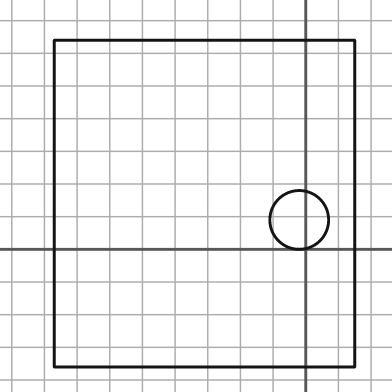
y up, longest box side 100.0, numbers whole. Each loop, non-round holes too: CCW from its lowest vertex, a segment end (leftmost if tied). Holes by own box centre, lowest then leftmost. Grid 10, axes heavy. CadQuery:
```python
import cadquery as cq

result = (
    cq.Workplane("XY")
    .moveTo(-77.0, -36.0)
    .lineTo(15.0, -36.0)
    .lineTo(15.0, 64.0)
    .lineTo(-77.0, 64.0)
    .close()
    .moveTo(-2.0, 9.0)
    .circle(9.0)
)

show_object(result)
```